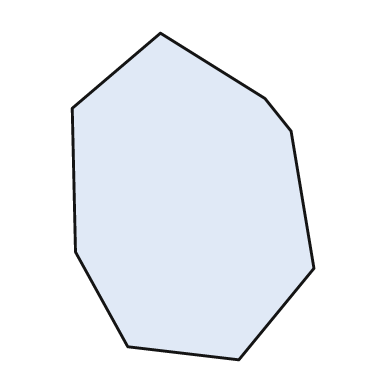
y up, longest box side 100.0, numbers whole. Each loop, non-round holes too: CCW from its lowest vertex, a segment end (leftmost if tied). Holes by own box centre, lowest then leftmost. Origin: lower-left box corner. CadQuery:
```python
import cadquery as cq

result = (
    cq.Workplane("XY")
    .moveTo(51.0, 0.0)
    .lineTo(74.0, 28.0)
    .lineTo(67.0, 70.0)
    .lineTo(59.0, 80.0)
    .lineTo(27.0, 100.0)
    .lineTo(0.0, 77.0)
    .lineTo(1.0, 33.0)
    .lineTo(17.0, 4.0)
    .close()
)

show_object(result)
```